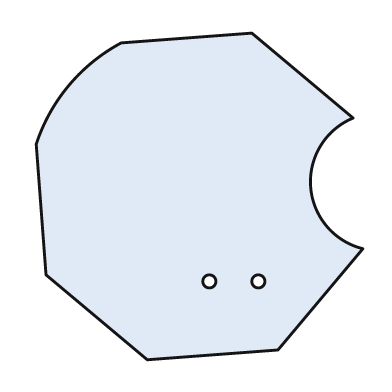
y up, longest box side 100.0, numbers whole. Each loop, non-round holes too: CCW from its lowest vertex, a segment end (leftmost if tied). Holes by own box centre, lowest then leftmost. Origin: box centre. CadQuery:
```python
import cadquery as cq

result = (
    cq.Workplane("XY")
    .moveTo(-16.0, -50.0)
    .lineTo(24.0, -47.0)
    .lineTo(50.0, -16.0)
    .threePointArc((34.0, 3.0), (47.0, 24.0))
    .lineTo(16.0, 50.0)
    .lineTo(-24.0, 47.0)
    .threePointArc((-40.0, 34.0), (-50.0, 16.0))
    .lineTo(-47.0, -24.0)
    .close()
    .moveTo(3.0, -26.0)
    .circle(2.0)
    .moveTo(18.0, -26.0)
    .circle(2.0)
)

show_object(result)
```